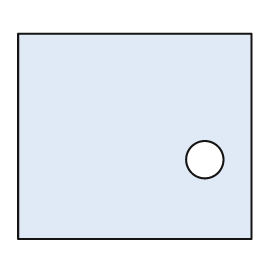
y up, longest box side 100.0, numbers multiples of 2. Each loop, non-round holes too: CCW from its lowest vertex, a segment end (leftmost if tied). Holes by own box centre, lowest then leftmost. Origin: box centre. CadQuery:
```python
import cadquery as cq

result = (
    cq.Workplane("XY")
    .moveTo(-50.0, -44.0)
    .lineTo(50.0, -44.0)
    .lineTo(50.0, 44.0)
    .lineTo(-50.0, 44.0)
    .close()
    .moveTo(30.0, -10.0)
    .circle(8.0)
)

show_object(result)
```